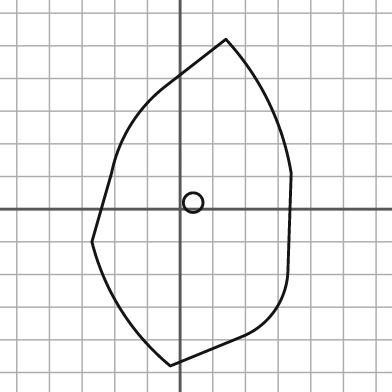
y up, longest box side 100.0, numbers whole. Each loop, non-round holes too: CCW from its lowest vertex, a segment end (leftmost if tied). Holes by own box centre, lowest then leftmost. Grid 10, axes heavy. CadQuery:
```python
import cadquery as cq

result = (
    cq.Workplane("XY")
    .moveTo(-3.0, -48.0)
    .lineTo(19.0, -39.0)
    .threePointArc((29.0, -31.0), (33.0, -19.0))
    .lineTo(34.0, 11.0)
    .threePointArc((27.0, 33.0), (14.0, 52.0))
    .lineTo(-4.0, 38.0)
    .threePointArc((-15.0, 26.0), (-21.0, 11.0))
    .lineTo(-27.0, -10.0)
    .threePointArc((-18.0, -31.0), (-3.0, -48.0))
    .close()
    .moveTo(4.0, 2.0)
    .circle(3.0)
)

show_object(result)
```